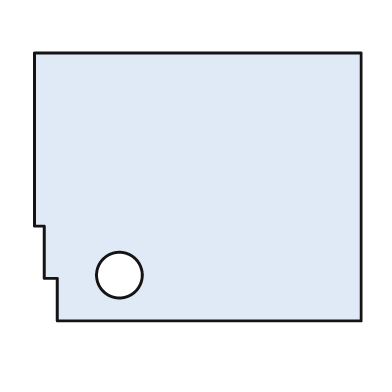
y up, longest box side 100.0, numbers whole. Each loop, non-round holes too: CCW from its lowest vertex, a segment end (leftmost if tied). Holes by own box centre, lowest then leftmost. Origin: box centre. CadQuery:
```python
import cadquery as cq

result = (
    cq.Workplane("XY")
    .moveTo(-43.0, -41.0)
    .lineTo(50.0, -41.0)
    .lineTo(50.0, 41.0)
    .lineTo(-50.0, 41.0)
    .lineTo(-50.0, -12.0)
    .lineTo(-47.0, -12.0)
    .lineTo(-47.0, -28.0)
    .lineTo(-43.0, -28.0)
    .close()
    .moveTo(-24.0, -27.0)
    .circle(7.0)
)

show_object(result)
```